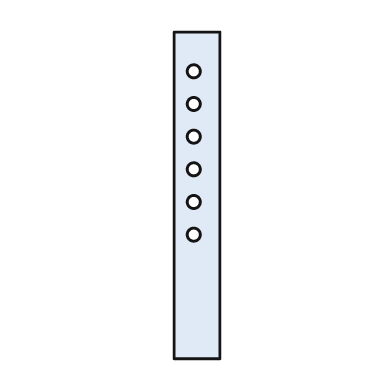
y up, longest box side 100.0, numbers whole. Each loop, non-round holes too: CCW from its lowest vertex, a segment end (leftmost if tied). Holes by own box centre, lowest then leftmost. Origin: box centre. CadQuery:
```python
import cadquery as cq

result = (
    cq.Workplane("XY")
    .moveTo(-7.0, -50.0)
    .lineTo(7.0, -50.0)
    .lineTo(7.0, 50.0)
    .lineTo(-7.0, 50.0)
    .close()
    .moveTo(-1.0, -12.0)
    .circle(2.0)
    .moveTo(-1.0, -2.0)
    .circle(2.0)
    .moveTo(-1.0, 8.0)
    .circle(2.0)
    .moveTo(-1.0, 18.0)
    .circle(2.0)
    .moveTo(-1.0, 28.0)
    .circle(2.0)
    .moveTo(-1.0, 38.0)
    .circle(2.0)
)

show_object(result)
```